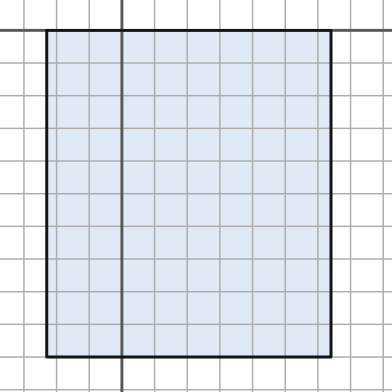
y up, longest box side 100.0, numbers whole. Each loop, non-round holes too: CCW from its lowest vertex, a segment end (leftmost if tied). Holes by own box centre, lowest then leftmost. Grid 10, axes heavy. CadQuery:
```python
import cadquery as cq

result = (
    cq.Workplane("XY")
    .moveTo(-23.0, -100.0)
    .lineTo(64.0, -100.0)
    .lineTo(64.0, 0.0)
    .lineTo(-23.0, 0.0)
    .close()
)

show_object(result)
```